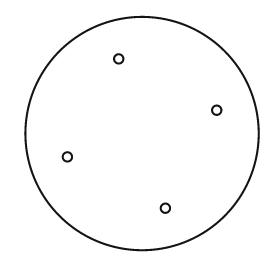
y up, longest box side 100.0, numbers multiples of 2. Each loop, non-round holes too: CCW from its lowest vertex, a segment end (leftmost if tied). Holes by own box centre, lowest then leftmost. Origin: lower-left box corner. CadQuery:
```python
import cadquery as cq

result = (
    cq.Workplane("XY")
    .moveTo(50.0, 50.0)
    .circle(50.0)
    .moveTo(60.0, 18.0)
    .circle(2.0)
    .moveTo(18.0, 40.0)
    .circle(2.0)
    .moveTo(82.0, 60.0)
    .circle(2.0)
    .moveTo(40.0, 82.0)
    .circle(2.0)
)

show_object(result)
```